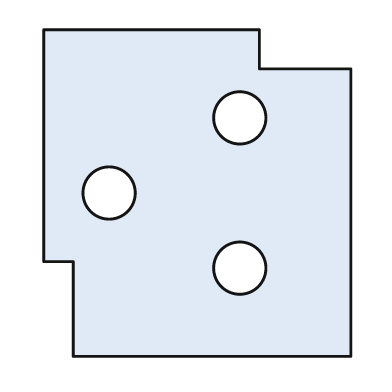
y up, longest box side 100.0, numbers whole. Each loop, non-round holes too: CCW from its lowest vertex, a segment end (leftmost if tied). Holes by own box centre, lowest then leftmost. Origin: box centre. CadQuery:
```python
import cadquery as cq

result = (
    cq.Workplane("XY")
    .moveTo(-38.0, -50.0)
    .lineTo(47.0, -50.0)
    .lineTo(47.0, 38.0)
    .lineTo(19.0, 38.0)
    .lineTo(19.0, 50.0)
    .lineTo(-47.0, 50.0)
    .lineTo(-47.0, -21.0)
    .lineTo(-38.0, -21.0)
    .close()
    .moveTo(13.0, -23.0)
    .circle(8.0)
    .moveTo(-27.0, 0.0)
    .circle(8.0)
    .moveTo(13.0, 23.0)
    .circle(8.0)
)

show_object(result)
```